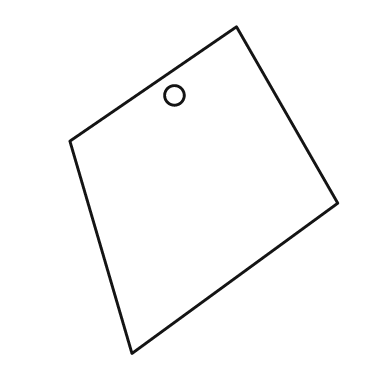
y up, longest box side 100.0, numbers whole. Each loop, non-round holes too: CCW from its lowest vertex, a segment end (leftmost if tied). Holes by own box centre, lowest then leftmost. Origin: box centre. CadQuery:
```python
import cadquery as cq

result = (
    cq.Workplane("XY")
    .moveTo(-22.0, -50.0)
    .lineTo(41.0, -4.0)
    .lineTo(10.0, 50.0)
    .lineTo(-41.0, 15.0)
    .close()
    .moveTo(-9.0, 29.0)
    .circle(3.0)
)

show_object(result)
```